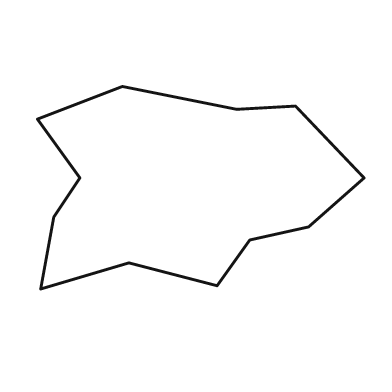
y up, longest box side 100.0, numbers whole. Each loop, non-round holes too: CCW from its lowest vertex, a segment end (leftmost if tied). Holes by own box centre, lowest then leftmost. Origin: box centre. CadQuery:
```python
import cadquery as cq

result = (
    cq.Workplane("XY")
    .moveTo(-49.0, -31.0)
    .lineTo(-22.0, -23.0)
    .lineTo(5.0, -30.0)
    .lineTo(15.0, -16.0)
    .lineTo(33.0, -12.0)
    .lineTo(50.0, 3.0)
    .lineTo(29.0, 25.0)
    .lineTo(11.0, 24.0)
    .lineTo(-24.0, 31.0)
    .lineTo(-50.0, 21.0)
    .lineTo(-37.0, 3.0)
    .lineTo(-45.0, -9.0)
    .close()
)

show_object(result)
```